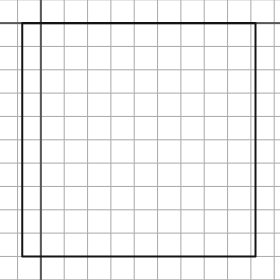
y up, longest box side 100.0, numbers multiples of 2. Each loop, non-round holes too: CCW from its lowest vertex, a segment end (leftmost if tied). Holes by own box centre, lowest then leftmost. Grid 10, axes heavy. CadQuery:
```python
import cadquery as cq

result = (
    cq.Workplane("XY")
    .moveTo(-8.0, -100.0)
    .lineTo(92.0, -100.0)
    .lineTo(92.0, 0.0)
    .lineTo(-8.0, 0.0)
    .close()
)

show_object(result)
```